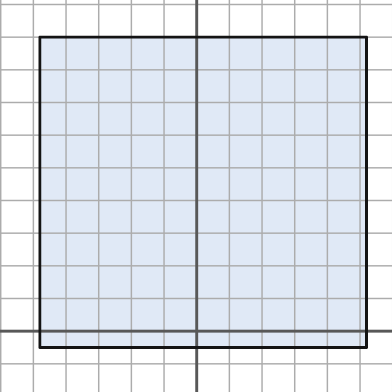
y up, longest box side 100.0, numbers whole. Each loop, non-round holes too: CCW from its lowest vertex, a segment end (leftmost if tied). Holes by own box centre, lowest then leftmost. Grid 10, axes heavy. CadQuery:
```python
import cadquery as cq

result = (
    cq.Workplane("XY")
    .moveTo(-48.0, -5.0)
    .lineTo(52.0, -5.0)
    .lineTo(52.0, 90.0)
    .lineTo(-48.0, 90.0)
    .close()
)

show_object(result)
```